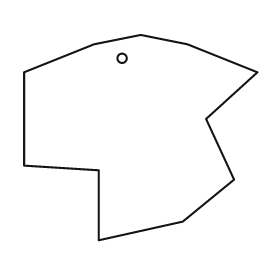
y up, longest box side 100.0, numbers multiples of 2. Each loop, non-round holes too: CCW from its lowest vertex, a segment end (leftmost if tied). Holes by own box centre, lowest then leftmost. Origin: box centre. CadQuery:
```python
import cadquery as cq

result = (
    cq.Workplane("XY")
    .moveTo(-18.0, -44.0)
    .lineTo(18.0, -36.0)
    .lineTo(40.0, -18.0)
    .lineTo(28.0, 8.0)
    .lineTo(50.0, 28.0)
    .lineTo(20.0, 40.0)
    .lineTo(0.0, 44.0)
    .lineTo(-20.0, 40.0)
    .lineTo(-50.0, 28.0)
    .lineTo(-50.0, -12.0)
    .lineTo(-18.0, -14.0)
    .close()
    .moveTo(-8.0, 34.0)
    .circle(2.0)
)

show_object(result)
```